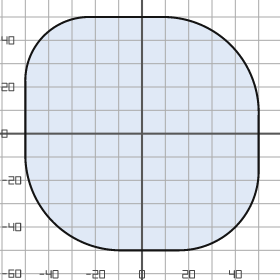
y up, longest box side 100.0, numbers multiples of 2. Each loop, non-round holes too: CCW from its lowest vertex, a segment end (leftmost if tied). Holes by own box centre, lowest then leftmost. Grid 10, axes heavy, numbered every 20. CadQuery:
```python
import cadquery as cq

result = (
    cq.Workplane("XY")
    .moveTo(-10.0, -50.0)
    .lineTo(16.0, -50.0)
    .threePointArc((40.0, -40.0), (50.0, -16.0))
    .lineTo(50.0, 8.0)
    .threePointArc((38.0, 38.0), (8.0, 50.0))
    .lineTo(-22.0, 50.0)
    .threePointArc((-42.0, 42.0), (-50.0, 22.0))
    .lineTo(-50.0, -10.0)
    .threePointArc((-38.0, -38.0), (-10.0, -50.0))
    .close()
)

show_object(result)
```